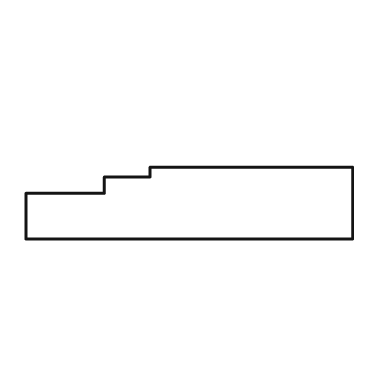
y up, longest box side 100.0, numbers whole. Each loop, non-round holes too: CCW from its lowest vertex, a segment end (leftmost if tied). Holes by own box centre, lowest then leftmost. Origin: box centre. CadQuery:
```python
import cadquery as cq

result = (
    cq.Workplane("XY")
    .moveTo(-50.0, -11.0)
    .lineTo(50.0, -11.0)
    .lineTo(50.0, 11.0)
    .lineTo(-12.0, 11.0)
    .lineTo(-12.0, 8.0)
    .lineTo(-26.0, 8.0)
    .lineTo(-26.0, 3.0)
    .lineTo(-50.0, 3.0)
    .close()
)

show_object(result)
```